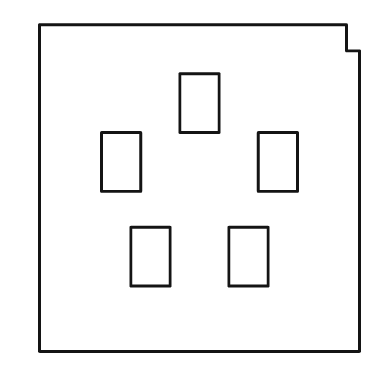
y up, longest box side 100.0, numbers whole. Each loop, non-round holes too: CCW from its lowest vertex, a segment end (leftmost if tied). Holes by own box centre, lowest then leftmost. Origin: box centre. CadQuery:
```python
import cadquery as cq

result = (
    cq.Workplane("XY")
    .moveTo(-49.0, -50.0)
    .lineTo(49.0, -50.0)
    .lineTo(49.0, 42.0)
    .lineTo(45.0, 42.0)
    .lineTo(45.0, 50.0)
    .lineTo(-49.0, 50.0)
    .close()
    .moveTo(-21.0, -30.0)
    .lineTo(-9.0, -30.0)
    .lineTo(-9.0, -12.0)
    .lineTo(-21.0, -12.0)
    .close()
    .moveTo(9.0, -30.0)
    .lineTo(21.0, -30.0)
    .lineTo(21.0, -12.0)
    .lineTo(9.0, -12.0)
    .close()
    .moveTo(-30.0, -1.0)
    .lineTo(-18.0, -1.0)
    .lineTo(-18.0, 17.0)
    .lineTo(-30.0, 17.0)
    .close()
    .moveTo(18.0, -1.0)
    .lineTo(30.0, -1.0)
    .lineTo(30.0, 17.0)
    .lineTo(18.0, 17.0)
    .close()
    .moveTo(-6.0, 17.0)
    .lineTo(6.0, 17.0)
    .lineTo(6.0, 35.0)
    .lineTo(-6.0, 35.0)
    .close()
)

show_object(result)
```